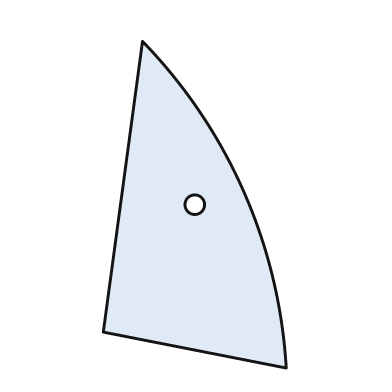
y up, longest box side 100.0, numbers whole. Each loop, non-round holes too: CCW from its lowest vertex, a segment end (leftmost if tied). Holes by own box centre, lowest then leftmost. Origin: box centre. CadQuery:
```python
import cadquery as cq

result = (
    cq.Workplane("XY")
    .moveTo(28.0, -50.0)
    .threePointArc((15.0, 4.0), (-16.0, 50.0))
    .lineTo(-28.0, -39.0)
    .close()
    .moveTo(0.0, 0.0)
    .circle(3.0)
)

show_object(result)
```